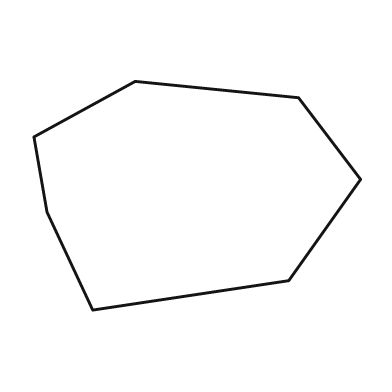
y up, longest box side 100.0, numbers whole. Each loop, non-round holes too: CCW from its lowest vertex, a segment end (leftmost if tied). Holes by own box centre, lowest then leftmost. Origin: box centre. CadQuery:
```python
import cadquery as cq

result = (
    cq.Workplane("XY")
    .moveTo(-32.0, -35.0)
    .lineTo(28.0, -26.0)
    .lineTo(50.0, 5.0)
    .lineTo(31.0, 30.0)
    .lineTo(-19.0, 35.0)
    .lineTo(-50.0, 18.0)
    .lineTo(-46.0, -5.0)
    .close()
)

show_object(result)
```